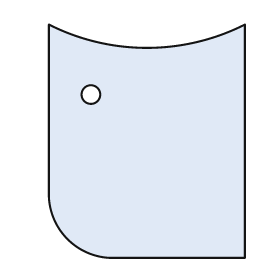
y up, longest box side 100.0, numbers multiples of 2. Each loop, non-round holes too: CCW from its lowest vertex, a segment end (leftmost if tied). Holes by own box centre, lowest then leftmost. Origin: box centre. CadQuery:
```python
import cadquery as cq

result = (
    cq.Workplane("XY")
    .moveTo(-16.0, -50.0)
    .lineTo(42.0, -50.0)
    .lineTo(42.0, 50.0)
    .threePointArc((0.0, 40.0), (-42.0, 50.0))
    .lineTo(-42.0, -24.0)
    .threePointArc((-34.0, -42.0), (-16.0, -50.0))
    .close()
    .moveTo(-24.0, 20.0)
    .circle(4.0)
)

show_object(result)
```